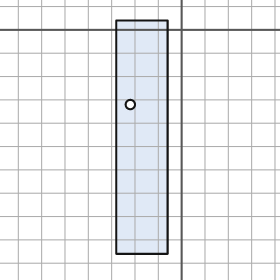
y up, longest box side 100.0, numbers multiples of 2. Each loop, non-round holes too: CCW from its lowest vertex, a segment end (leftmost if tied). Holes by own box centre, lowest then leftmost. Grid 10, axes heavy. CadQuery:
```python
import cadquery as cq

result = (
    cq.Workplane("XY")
    .moveTo(-28.0, -96.0)
    .lineTo(-6.0, -96.0)
    .lineTo(-6.0, 4.0)
    .lineTo(-28.0, 4.0)
    .close()
    .moveTo(-22.0, -32.0)
    .circle(2.0)
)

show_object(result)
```